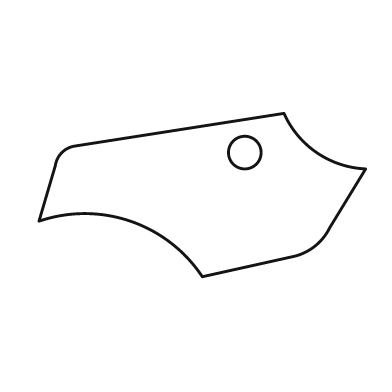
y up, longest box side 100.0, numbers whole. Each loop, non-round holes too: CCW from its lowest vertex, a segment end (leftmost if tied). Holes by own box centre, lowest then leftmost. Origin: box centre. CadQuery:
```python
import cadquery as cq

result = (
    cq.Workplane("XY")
    .moveTo(0.0, -25.0)
    .lineTo(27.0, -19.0)
    .threePointArc((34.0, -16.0), (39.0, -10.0))
    .lineTo(50.0, 8.0)
    .threePointArc((35.0, 13.0), (25.0, 25.0))
    .lineTo(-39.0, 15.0)
    .threePointArc((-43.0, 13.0), (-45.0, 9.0))
    .lineTo(-50.0, -8.0)
    .threePointArc((-22.0, -8.0), (0.0, -25.0))
    .close()
    .moveTo(13.0, 13.0)
    .circle(5.0)
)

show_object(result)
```